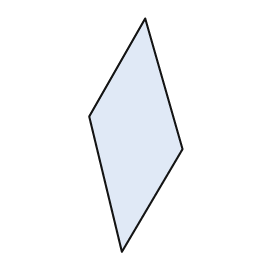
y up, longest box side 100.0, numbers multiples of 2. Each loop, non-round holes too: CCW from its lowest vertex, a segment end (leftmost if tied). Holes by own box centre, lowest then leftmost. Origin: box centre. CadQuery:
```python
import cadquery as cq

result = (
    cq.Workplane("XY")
    .moveTo(-6.0, -50.0)
    .lineTo(20.0, -6.0)
    .lineTo(4.0, 50.0)
    .lineTo(-20.0, 8.0)
    .close()
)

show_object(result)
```